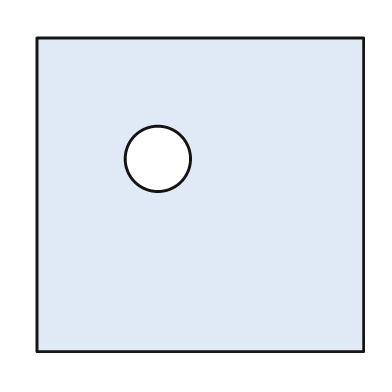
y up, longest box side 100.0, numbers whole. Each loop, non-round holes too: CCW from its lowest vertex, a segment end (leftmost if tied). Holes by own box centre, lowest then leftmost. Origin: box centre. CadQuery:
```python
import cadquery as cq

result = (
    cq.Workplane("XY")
    .moveTo(-50.0, -48.0)
    .lineTo(50.0, -48.0)
    .lineTo(50.0, 48.0)
    .lineTo(-50.0, 48.0)
    .close()
    .moveTo(-13.0, 11.0)
    .circle(10.0)
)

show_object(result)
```